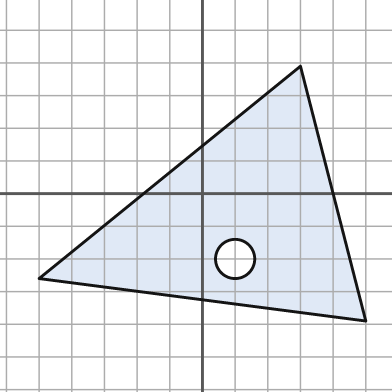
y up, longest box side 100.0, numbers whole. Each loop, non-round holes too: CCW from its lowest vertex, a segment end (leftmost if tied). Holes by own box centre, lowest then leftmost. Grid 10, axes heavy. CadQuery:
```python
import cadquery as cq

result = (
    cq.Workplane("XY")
    .moveTo(50.0, -39.0)
    .lineTo(30.0, 39.0)
    .lineTo(-50.0, -26.0)
    .close()
    .moveTo(10.0, -20.0)
    .circle(6.0)
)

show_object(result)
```